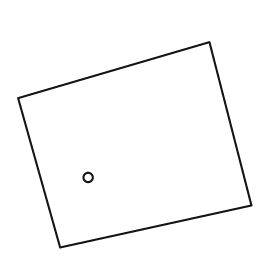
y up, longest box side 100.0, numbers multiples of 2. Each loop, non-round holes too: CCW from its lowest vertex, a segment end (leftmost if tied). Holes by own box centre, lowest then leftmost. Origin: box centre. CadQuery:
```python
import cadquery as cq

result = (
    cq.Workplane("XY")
    .moveTo(-32.0, -44.0)
    .lineTo(50.0, -26.0)
    .lineTo(32.0, 44.0)
    .lineTo(-50.0, 20.0)
    .close()
    .moveTo(-20.0, -14.0)
    .circle(2.0)
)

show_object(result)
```